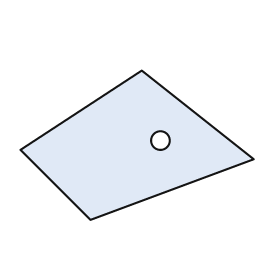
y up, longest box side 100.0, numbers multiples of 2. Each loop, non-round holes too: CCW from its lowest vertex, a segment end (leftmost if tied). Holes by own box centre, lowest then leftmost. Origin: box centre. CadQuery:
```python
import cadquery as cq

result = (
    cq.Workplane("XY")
    .moveTo(-20.0, -32.0)
    .lineTo(50.0, -6.0)
    .lineTo(2.0, 32.0)
    .lineTo(-50.0, -2.0)
    .close()
    .moveTo(10.0, 2.0)
    .circle(4.0)
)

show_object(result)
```